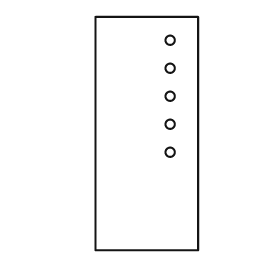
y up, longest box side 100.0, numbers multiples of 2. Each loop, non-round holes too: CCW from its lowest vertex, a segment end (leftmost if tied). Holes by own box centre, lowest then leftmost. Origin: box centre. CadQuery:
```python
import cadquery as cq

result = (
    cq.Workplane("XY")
    .moveTo(-22.0, -50.0)
    .lineTo(22.0, -50.0)
    .lineTo(22.0, 50.0)
    .lineTo(-22.0, 50.0)
    .close()
    .moveTo(10.0, -8.0)
    .circle(2.0)
    .moveTo(10.0, 4.0)
    .circle(2.0)
    .moveTo(10.0, 16.0)
    .circle(2.0)
    .moveTo(10.0, 28.0)
    .circle(2.0)
    .moveTo(10.0, 40.0)
    .circle(2.0)
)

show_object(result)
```